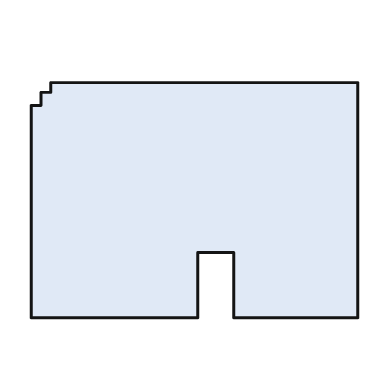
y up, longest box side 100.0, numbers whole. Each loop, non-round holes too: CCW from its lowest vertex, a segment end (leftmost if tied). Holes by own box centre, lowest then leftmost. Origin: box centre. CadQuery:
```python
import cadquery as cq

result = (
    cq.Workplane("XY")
    .moveTo(-50.0, -36.0)
    .lineTo(1.0, -36.0)
    .lineTo(1.0, -16.0)
    .lineTo(12.0, -16.0)
    .lineTo(12.0, -36.0)
    .lineTo(50.0, -36.0)
    .lineTo(50.0, 36.0)
    .lineTo(-44.0, 36.0)
    .lineTo(-44.0, 33.0)
    .lineTo(-47.0, 33.0)
    .lineTo(-47.0, 29.0)
    .lineTo(-50.0, 29.0)
    .close()
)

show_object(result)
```